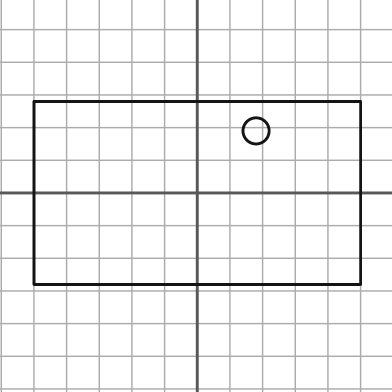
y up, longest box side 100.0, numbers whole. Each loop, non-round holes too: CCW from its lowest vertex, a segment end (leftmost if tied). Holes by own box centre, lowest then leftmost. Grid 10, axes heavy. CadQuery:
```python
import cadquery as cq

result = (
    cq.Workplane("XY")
    .moveTo(-50.0, -28.0)
    .lineTo(50.0, -28.0)
    .lineTo(50.0, 28.0)
    .lineTo(-50.0, 28.0)
    .close()
    .moveTo(18.0, 19.0)
    .circle(4.0)
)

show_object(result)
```